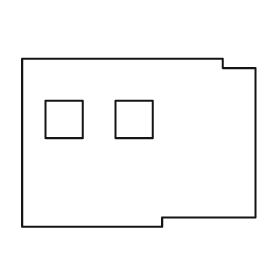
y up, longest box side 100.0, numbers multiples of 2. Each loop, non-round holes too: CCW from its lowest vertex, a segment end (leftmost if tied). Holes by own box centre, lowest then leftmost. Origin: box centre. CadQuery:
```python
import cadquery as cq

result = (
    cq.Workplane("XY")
    .moveTo(-50.0, -36.0)
    .lineTo(10.0, -36.0)
    .lineTo(10.0, -32.0)
    .lineTo(50.0, -32.0)
    .lineTo(50.0, 32.0)
    .lineTo(36.0, 32.0)
    .lineTo(36.0, 36.0)
    .lineTo(-50.0, 36.0)
    .close()
    .moveTo(-40.0, 2.0)
    .lineTo(-24.0, 2.0)
    .lineTo(-24.0, 18.0)
    .lineTo(-40.0, 18.0)
    .close()
    .moveTo(-10.0, 2.0)
    .lineTo(6.0, 2.0)
    .lineTo(6.0, 18.0)
    .lineTo(-10.0, 18.0)
    .close()
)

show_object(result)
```